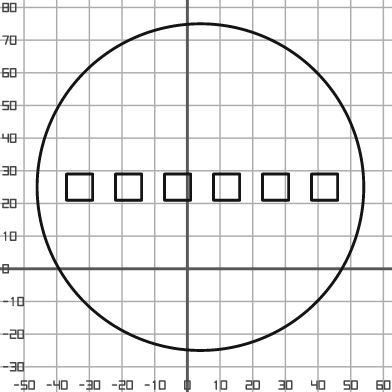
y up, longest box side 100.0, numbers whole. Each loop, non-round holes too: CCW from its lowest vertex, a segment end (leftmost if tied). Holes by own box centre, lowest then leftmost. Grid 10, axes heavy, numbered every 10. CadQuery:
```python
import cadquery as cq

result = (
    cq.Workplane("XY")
    .moveTo(4.0, 25.0)
    .circle(50.0)
    .moveTo(-37.0, 21.0)
    .lineTo(-29.0, 21.0)
    .lineTo(-29.0, 29.0)
    .lineTo(-37.0, 29.0)
    .close()
    .moveTo(-22.0, 21.0)
    .lineTo(-14.0, 21.0)
    .lineTo(-14.0, 29.0)
    .lineTo(-22.0, 29.0)
    .close()
    .moveTo(-7.0, 21.0)
    .lineTo(1.0, 21.0)
    .lineTo(1.0, 29.0)
    .lineTo(-7.0, 29.0)
    .close()
    .moveTo(8.0, 21.0)
    .lineTo(16.0, 21.0)
    .lineTo(16.0, 29.0)
    .lineTo(8.0, 29.0)
    .close()
    .moveTo(23.0, 21.0)
    .lineTo(31.0, 21.0)
    .lineTo(31.0, 29.0)
    .lineTo(23.0, 29.0)
    .close()
    .moveTo(38.0, 21.0)
    .lineTo(46.0, 21.0)
    .lineTo(46.0, 29.0)
    .lineTo(38.0, 29.0)
    .close()
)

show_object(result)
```